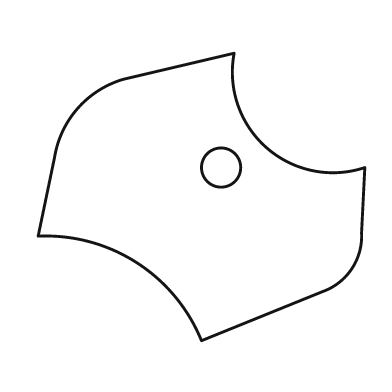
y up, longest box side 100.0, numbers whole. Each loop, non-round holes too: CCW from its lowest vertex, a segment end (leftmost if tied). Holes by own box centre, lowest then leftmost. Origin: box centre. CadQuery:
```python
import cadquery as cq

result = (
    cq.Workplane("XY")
    .moveTo(0.0, -44.0)
    .lineTo(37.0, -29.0)
    .threePointArc((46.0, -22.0), (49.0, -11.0))
    .lineTo(50.0, 9.0)
    .threePointArc((20.0, 15.0), (10.0, 44.0))
    .lineTo(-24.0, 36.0)
    .threePointArc((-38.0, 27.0), (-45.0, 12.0))
    .lineTo(-50.0, -12.0)
    .threePointArc((-20.0, -20.0), (0.0, -44.0))
    .close()
    .moveTo(6.0, 9.0)
    .circle(6.0)
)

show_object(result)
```